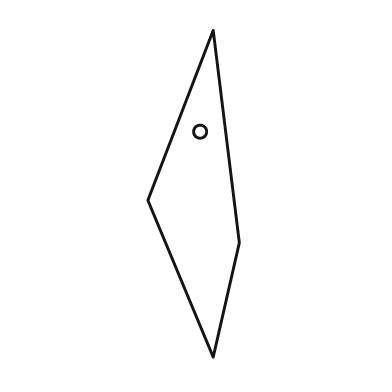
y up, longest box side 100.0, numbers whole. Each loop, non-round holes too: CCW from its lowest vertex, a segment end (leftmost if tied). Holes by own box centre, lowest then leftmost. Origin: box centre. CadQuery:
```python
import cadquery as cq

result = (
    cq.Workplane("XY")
    .moveTo(6.0, -50.0)
    .lineTo(14.0, -15.0)
    .lineTo(6.0, 50.0)
    .lineTo(-14.0, -2.0)
    .close()
    .moveTo(2.0, 19.0)
    .circle(2.0)
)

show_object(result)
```